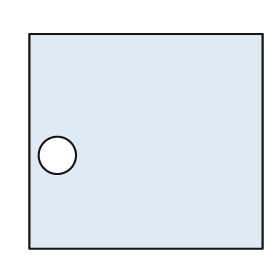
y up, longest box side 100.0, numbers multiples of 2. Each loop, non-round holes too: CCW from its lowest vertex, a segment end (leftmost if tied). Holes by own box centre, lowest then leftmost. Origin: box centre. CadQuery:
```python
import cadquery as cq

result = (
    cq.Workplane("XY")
    .moveTo(-50.0, -46.0)
    .lineTo(50.0, -46.0)
    .lineTo(50.0, 46.0)
    .lineTo(-50.0, 46.0)
    .close()
    .moveTo(-38.0, -6.0)
    .circle(8.0)
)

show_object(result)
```